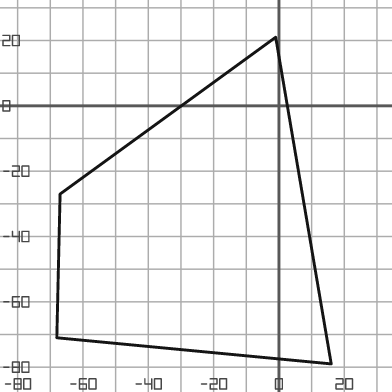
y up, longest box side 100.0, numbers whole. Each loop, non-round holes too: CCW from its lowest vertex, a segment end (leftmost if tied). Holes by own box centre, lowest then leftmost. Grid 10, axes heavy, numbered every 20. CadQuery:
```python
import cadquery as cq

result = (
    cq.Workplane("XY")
    .moveTo(16.0, -79.0)
    .lineTo(-1.0, 21.0)
    .lineTo(-67.0, -27.0)
    .lineTo(-68.0, -71.0)
    .close()
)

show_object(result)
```